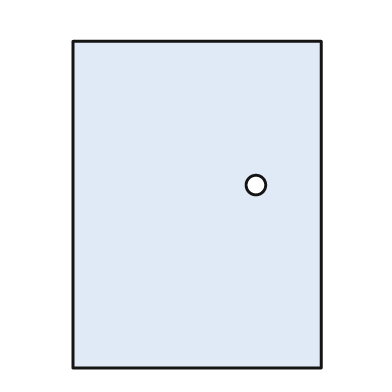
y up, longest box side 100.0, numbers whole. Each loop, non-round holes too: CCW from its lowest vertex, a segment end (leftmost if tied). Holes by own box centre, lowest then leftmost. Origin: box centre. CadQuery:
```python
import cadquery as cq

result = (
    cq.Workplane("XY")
    .moveTo(-38.0, -50.0)
    .lineTo(38.0, -50.0)
    .lineTo(38.0, 50.0)
    .lineTo(-38.0, 50.0)
    .close()
    .moveTo(18.0, 6.0)
    .circle(3.0)
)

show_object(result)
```